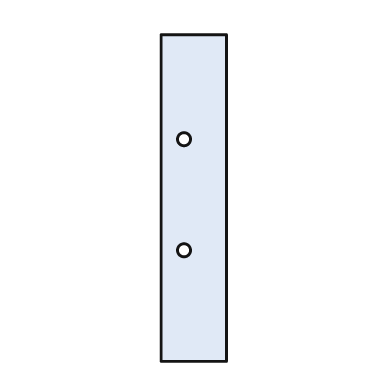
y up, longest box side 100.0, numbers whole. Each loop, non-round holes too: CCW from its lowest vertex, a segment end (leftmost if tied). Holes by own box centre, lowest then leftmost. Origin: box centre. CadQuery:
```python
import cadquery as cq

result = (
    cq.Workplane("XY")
    .moveTo(-10.0, -50.0)
    .lineTo(10.0, -50.0)
    .lineTo(10.0, 50.0)
    .lineTo(-10.0, 50.0)
    .close()
    .moveTo(-3.0, -16.0)
    .circle(2.0)
    .moveTo(-3.0, 18.0)
    .circle(2.0)
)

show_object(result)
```